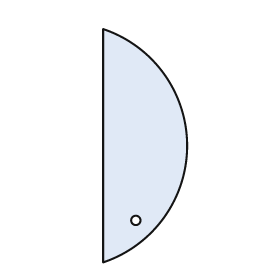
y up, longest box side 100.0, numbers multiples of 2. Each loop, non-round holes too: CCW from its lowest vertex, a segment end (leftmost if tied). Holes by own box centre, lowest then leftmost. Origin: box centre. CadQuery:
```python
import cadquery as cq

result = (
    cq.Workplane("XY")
    .moveTo(-18.0, -50.0)
    .threePointArc((18.0, 0.0), (-18.0, 50.0))
    .close()
    .moveTo(-4.0, -32.0)
    .circle(2.0)
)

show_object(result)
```